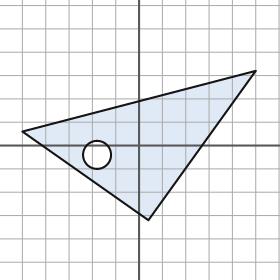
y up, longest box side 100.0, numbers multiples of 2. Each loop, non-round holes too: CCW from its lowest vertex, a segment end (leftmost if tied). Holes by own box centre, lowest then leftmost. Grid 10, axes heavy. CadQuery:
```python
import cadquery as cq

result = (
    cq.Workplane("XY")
    .moveTo(4.0, -32.0)
    .lineTo(50.0, 32.0)
    .lineTo(-50.0, 6.0)
    .close()
    .moveTo(-18.0, -4.0)
    .circle(6.0)
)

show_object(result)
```